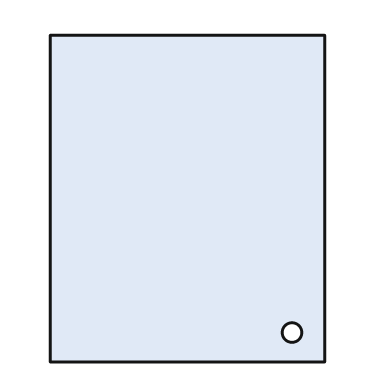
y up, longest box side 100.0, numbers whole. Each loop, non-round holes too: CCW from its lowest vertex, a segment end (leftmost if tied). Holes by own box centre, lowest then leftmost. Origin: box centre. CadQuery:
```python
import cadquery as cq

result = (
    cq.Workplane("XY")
    .moveTo(-42.0, -50.0)
    .lineTo(42.0, -50.0)
    .lineTo(42.0, 50.0)
    .lineTo(-42.0, 50.0)
    .close()
    .moveTo(32.0, -41.0)
    .circle(3.0)
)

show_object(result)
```